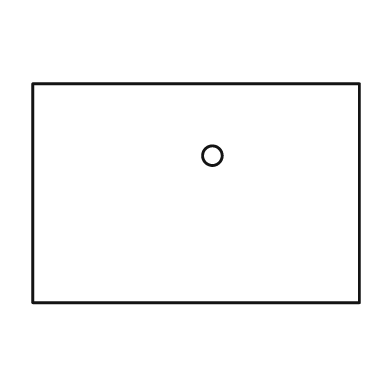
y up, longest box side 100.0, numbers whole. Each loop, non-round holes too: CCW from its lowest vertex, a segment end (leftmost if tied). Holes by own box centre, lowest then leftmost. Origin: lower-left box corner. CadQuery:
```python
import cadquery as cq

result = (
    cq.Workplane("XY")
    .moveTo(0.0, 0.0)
    .lineTo(100.0, 0.0)
    .lineTo(100.0, 67.0)
    .lineTo(0.0, 67.0)
    .close()
    .moveTo(55.0, 45.0)
    .circle(3.0)
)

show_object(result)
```